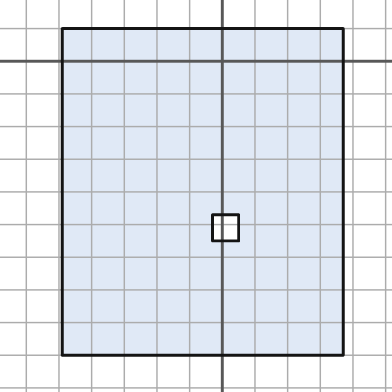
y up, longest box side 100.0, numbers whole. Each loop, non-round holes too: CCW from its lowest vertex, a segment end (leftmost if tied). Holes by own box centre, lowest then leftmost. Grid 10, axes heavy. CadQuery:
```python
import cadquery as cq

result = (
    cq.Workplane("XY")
    .moveTo(-49.0, -90.0)
    .lineTo(37.0, -90.0)
    .lineTo(37.0, 10.0)
    .lineTo(-49.0, 10.0)
    .close()
    .moveTo(-3.0, -55.0)
    .lineTo(5.0, -55.0)
    .lineTo(5.0, -47.0)
    .lineTo(-3.0, -47.0)
    .close()
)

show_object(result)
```